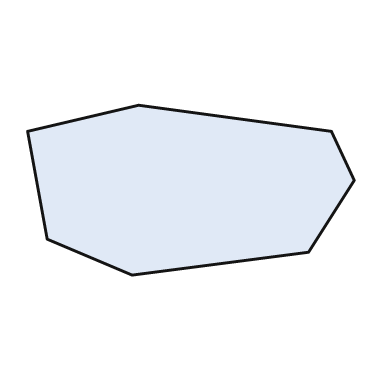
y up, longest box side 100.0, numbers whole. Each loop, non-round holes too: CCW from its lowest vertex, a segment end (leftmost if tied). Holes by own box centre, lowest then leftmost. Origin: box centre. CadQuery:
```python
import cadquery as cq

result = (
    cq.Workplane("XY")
    .moveTo(-18.0, -26.0)
    .lineTo(36.0, -19.0)
    .lineTo(50.0, 3.0)
    .lineTo(43.0, 18.0)
    .lineTo(-16.0, 26.0)
    .lineTo(-50.0, 18.0)
    .lineTo(-44.0, -15.0)
    .close()
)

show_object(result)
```